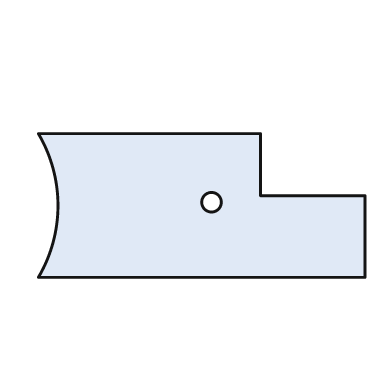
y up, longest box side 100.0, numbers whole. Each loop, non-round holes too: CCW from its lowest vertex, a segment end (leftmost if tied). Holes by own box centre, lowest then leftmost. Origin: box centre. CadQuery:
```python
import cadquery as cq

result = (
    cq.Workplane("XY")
    .moveTo(-50.0, -22.0)
    .lineTo(50.0, -22.0)
    .lineTo(50.0, 3.0)
    .lineTo(18.0, 3.0)
    .lineTo(18.0, 22.0)
    .lineTo(-50.0, 22.0)
    .threePointArc((-44.0, 0.0), (-50.0, -22.0))
    .close()
    .moveTo(3.0, 1.0)
    .circle(3.0)
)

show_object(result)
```